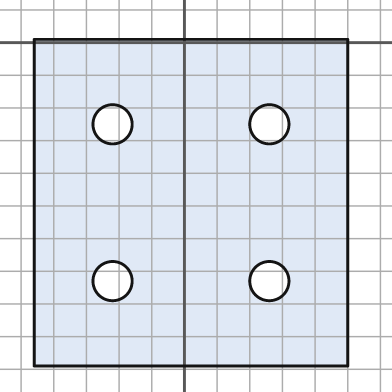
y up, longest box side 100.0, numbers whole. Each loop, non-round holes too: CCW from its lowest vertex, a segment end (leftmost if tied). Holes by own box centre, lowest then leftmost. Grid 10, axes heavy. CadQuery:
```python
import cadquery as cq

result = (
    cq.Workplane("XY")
    .moveTo(-46.0, -99.0)
    .lineTo(50.0, -99.0)
    .lineTo(50.0, 1.0)
    .lineTo(-46.0, 1.0)
    .close()
    .moveTo(-22.0, -73.0)
    .circle(6.0)
    .moveTo(26.0, -73.0)
    .circle(6.0)
    .moveTo(-22.0, -25.0)
    .circle(6.0)
    .moveTo(26.0, -25.0)
    .circle(6.0)
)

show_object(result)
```